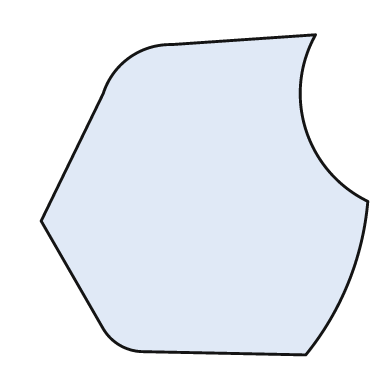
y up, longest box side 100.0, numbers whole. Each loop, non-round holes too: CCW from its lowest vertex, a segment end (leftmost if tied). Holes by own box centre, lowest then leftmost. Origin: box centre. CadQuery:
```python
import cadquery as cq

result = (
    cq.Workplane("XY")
    .moveTo(31.0, -49.0)
    .threePointArc((44.0, -27.0), (50.0, -2.0))
    .threePointArc((31.0, 20.0), (34.0, 49.0))
    .lineTo(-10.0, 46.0)
    .threePointArc((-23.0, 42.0), (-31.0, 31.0))
    .lineTo(-50.0, -8.0)
    .lineTo(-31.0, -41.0)
    .threePointArc((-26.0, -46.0), (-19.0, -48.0))
    .close()
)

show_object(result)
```